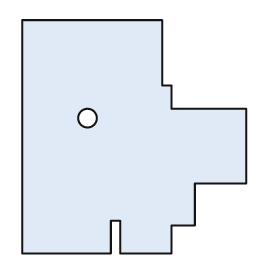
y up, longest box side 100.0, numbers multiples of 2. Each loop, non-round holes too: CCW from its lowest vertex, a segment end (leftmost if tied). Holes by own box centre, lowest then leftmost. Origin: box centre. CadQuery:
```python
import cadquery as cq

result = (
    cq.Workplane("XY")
    .moveTo(-48.0, -50.0)
    .lineTo(-10.0, -50.0)
    .lineTo(-10.0, -36.0)
    .lineTo(-6.0, -36.0)
    .lineTo(-6.0, -50.0)
    .lineTo(16.0, -50.0)
    .lineTo(16.0, -38.0)
    .lineTo(26.0, -38.0)
    .lineTo(26.0, -20.0)
    .lineTo(48.0, -20.0)
    .lineTo(48.0, 12.0)
    .lineTo(16.0, 12.0)
    .lineTo(16.0, 22.0)
    .lineTo(12.0, 22.0)
    .lineTo(12.0, 50.0)
    .lineTo(-48.0, 50.0)
    .close()
    .moveTo(-20.0, 8.0)
    .circle(4.0)
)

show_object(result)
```